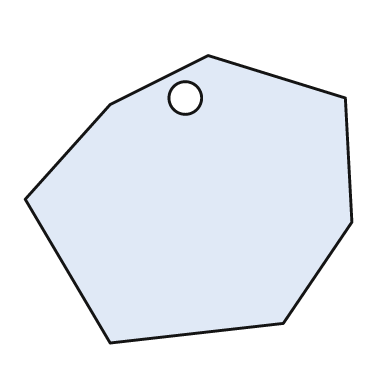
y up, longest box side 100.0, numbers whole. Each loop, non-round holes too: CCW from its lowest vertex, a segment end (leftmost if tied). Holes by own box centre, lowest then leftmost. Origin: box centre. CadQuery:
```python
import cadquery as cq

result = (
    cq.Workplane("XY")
    .moveTo(-24.0, -44.0)
    .lineTo(29.0, -38.0)
    .lineTo(50.0, -7.0)
    .lineTo(48.0, 31.0)
    .lineTo(6.0, 44.0)
    .lineTo(-24.0, 29.0)
    .lineTo(-50.0, 0.0)
    .close()
    .moveTo(-1.0, 31.0)
    .circle(5.0)
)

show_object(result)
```